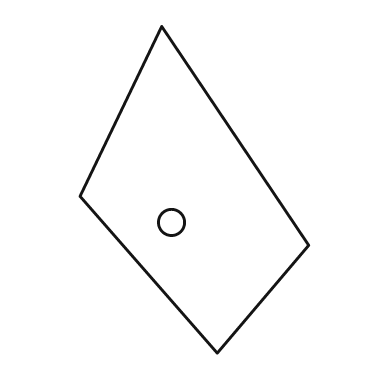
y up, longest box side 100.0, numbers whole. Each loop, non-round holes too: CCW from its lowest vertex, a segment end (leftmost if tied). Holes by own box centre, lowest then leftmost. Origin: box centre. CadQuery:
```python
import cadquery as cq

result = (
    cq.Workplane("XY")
    .moveTo(7.0, -50.0)
    .lineTo(35.0, -17.0)
    .lineTo(-10.0, 50.0)
    .lineTo(-35.0, -2.0)
    .close()
    .moveTo(-7.0, -10.0)
    .circle(4.0)
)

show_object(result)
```